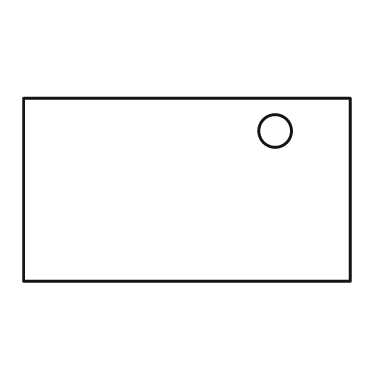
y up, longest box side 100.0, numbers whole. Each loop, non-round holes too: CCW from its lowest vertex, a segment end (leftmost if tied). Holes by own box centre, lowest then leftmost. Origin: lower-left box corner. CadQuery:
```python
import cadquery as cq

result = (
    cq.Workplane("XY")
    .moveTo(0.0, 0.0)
    .lineTo(100.0, 0.0)
    .lineTo(100.0, 56.0)
    .lineTo(0.0, 56.0)
    .close()
    .moveTo(77.0, 46.0)
    .circle(5.0)
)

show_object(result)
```